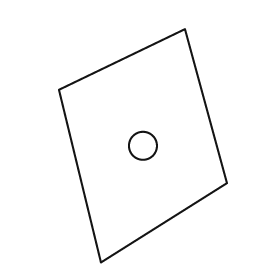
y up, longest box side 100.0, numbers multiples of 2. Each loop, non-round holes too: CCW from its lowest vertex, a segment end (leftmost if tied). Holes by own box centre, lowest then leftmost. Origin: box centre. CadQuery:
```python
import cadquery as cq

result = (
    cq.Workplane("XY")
    .moveTo(-18.0, -50.0)
    .lineTo(36.0, -16.0)
    .lineTo(18.0, 50.0)
    .lineTo(-36.0, 24.0)
    .close()
    .moveTo(0.0, 0.0)
    .circle(6.0)
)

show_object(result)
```